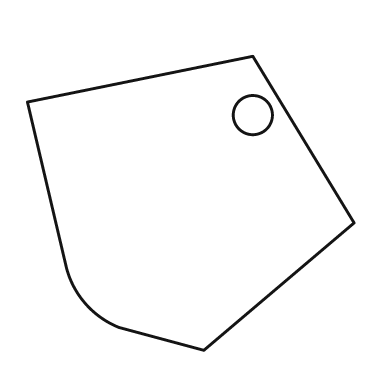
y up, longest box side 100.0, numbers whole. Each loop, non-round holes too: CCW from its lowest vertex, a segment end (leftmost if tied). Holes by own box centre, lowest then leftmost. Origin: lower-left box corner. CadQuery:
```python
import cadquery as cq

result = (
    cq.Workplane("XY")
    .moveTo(54.0, 0.0)
    .lineTo(100.0, 39.0)
    .lineTo(69.0, 90.0)
    .lineTo(0.0, 76.0)
    .lineTo(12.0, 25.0)
    .threePointArc((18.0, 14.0), (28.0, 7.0))
    .close()
    .moveTo(69.0, 72.0)
    .circle(6.0)
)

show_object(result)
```